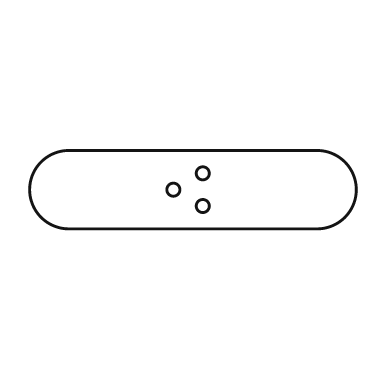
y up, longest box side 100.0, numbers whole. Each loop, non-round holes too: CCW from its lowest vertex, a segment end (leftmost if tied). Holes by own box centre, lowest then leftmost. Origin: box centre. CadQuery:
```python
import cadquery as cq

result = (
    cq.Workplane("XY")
    .moveTo(-38.0, -12.0)
    .lineTo(38.0, -12.0)
    .threePointArc((50.0, 0.0), (38.0, 12.0))
    .lineTo(-38.0, 12.0)
    .threePointArc((-50.0, 0.0), (-38.0, -12.0))
    .close()
    .moveTo(3.0, -5.0)
    .circle(2.0)
    .moveTo(-6.0, 0.0)
    .circle(2.0)
    .moveTo(3.0, 5.0)
    .circle(2.0)
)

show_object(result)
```